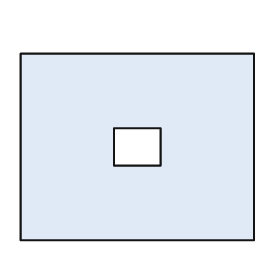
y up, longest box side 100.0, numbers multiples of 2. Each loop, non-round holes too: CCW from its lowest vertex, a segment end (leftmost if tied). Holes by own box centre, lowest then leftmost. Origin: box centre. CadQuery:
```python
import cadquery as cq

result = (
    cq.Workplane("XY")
    .moveTo(-50.0, -40.0)
    .lineTo(50.0, -40.0)
    .lineTo(50.0, 40.0)
    .lineTo(-50.0, 40.0)
    .close()
    .moveTo(-10.0, -8.0)
    .lineTo(10.0, -8.0)
    .lineTo(10.0, 8.0)
    .lineTo(-10.0, 8.0)
    .close()
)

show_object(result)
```